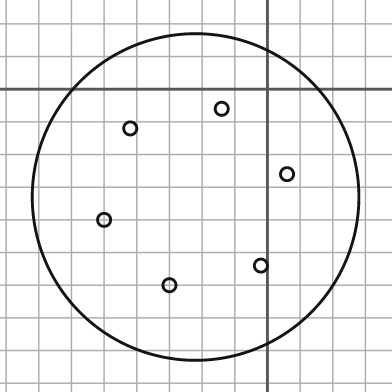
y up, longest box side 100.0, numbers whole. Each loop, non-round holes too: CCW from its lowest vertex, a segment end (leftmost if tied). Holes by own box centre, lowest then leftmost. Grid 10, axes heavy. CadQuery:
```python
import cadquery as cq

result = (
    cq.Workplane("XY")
    .moveTo(-22.0, -33.0)
    .circle(50.0)
    .moveTo(-30.0, -60.0)
    .circle(2.0)
    .moveTo(-2.0, -54.0)
    .circle(2.0)
    .moveTo(-50.0, -40.0)
    .circle(2.0)
    .moveTo(6.0, -26.0)
    .circle(2.0)
    .moveTo(-42.0, -12.0)
    .circle(2.0)
    .moveTo(-14.0, -6.0)
    .circle(2.0)
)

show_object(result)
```